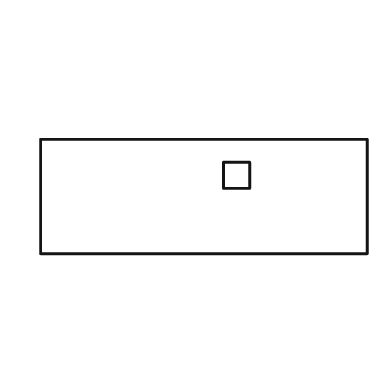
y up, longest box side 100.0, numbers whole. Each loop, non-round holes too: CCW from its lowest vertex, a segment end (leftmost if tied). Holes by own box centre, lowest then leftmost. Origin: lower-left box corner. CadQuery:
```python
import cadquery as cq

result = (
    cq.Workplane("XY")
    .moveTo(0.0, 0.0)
    .lineTo(100.0, 0.0)
    .lineTo(100.0, 35.0)
    .lineTo(0.0, 35.0)
    .close()
    .moveTo(56.0, 20.0)
    .lineTo(64.0, 20.0)
    .lineTo(64.0, 28.0)
    .lineTo(56.0, 28.0)
    .close()
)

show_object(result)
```